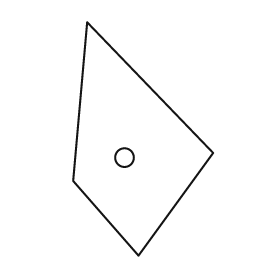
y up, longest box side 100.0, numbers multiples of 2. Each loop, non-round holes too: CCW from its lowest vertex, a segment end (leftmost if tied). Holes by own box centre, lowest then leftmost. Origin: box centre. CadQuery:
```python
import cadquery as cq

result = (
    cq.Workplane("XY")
    .moveTo(-2.0, -50.0)
    .lineTo(30.0, -6.0)
    .lineTo(-24.0, 50.0)
    .lineTo(-30.0, -18.0)
    .close()
    .moveTo(-8.0, -8.0)
    .circle(4.0)
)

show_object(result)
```